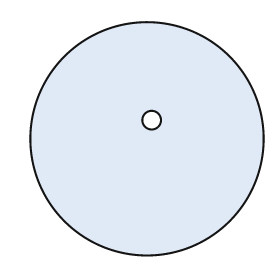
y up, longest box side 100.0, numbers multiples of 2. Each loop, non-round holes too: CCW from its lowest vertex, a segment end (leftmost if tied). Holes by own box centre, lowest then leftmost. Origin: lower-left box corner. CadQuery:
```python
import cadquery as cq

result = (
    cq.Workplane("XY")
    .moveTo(50.0, 50.0)
    .circle(50.0)
    .moveTo(52.0, 58.0)
    .circle(4.0)
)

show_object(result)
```